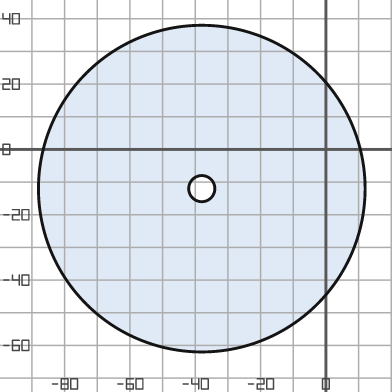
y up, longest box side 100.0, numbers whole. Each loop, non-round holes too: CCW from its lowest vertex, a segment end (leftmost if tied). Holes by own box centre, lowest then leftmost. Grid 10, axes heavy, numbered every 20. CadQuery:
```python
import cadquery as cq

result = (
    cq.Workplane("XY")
    .moveTo(-38.0, -12.0)
    .circle(50.0)
    .moveTo(-38.0, -12.0)
    .circle(4.0)
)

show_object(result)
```